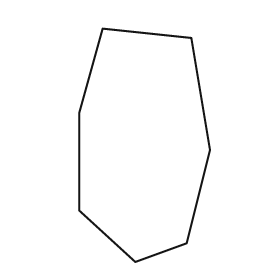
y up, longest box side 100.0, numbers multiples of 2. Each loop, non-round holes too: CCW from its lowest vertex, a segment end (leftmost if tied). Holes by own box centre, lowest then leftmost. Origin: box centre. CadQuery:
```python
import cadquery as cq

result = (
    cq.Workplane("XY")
    .moveTo(-4.0, -50.0)
    .lineTo(18.0, -42.0)
    .lineTo(28.0, -2.0)
    .lineTo(20.0, 46.0)
    .lineTo(-18.0, 50.0)
    .lineTo(-28.0, 14.0)
    .lineTo(-28.0, -28.0)
    .close()
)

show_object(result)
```